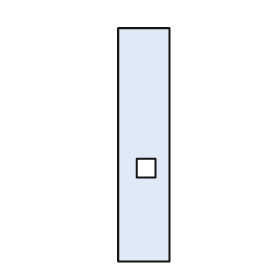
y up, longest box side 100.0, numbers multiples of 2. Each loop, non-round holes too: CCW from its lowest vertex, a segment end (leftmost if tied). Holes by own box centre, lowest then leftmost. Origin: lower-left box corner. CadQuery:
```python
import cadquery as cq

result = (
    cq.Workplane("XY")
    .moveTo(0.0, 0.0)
    .lineTo(22.0, 0.0)
    .lineTo(22.0, 100.0)
    .lineTo(0.0, 100.0)
    .close()
    .moveTo(8.0, 36.0)
    .lineTo(16.0, 36.0)
    .lineTo(16.0, 44.0)
    .lineTo(8.0, 44.0)
    .close()
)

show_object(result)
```